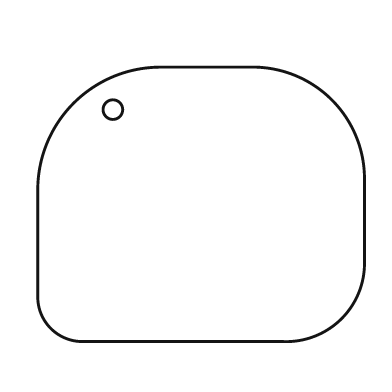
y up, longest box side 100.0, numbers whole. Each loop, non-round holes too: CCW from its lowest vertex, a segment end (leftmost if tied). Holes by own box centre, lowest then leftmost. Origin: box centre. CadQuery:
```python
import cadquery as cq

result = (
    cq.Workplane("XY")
    .moveTo(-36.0, -42.0)
    .lineTo(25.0, -42.0)
    .threePointArc((43.0, -35.0), (50.0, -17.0))
    .lineTo(50.0, 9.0)
    .threePointArc((40.0, 32.0), (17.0, 42.0))
    .lineTo(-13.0, 42.0)
    .threePointArc((-39.0, 31.0), (-50.0, 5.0))
    .lineTo(-50.0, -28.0)
    .threePointArc((-46.0, -38.0), (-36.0, -42.0))
    .close()
    .moveTo(-27.0, 29.0)
    .circle(3.0)
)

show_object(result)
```